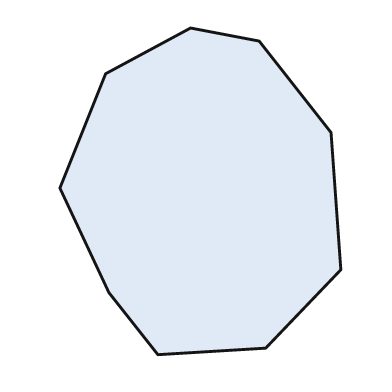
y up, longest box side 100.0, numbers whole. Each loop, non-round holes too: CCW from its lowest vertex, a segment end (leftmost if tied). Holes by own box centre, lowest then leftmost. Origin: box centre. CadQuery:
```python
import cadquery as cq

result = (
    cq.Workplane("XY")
    .moveTo(-13.0, -50.0)
    .lineTo(20.0, -48.0)
    .lineTo(43.0, -24.0)
    .lineTo(40.0, 18.0)
    .lineTo(18.0, 46.0)
    .lineTo(-3.0, 50.0)
    .lineTo(-29.0, 36.0)
    .lineTo(-43.0, 1.0)
    .lineTo(-28.0, -31.0)
    .close()
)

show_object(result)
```